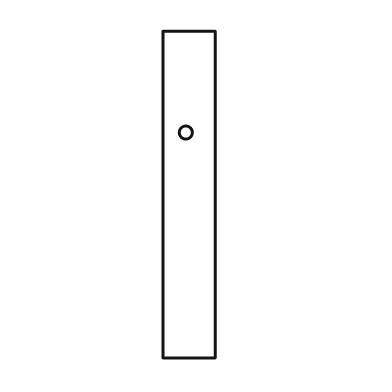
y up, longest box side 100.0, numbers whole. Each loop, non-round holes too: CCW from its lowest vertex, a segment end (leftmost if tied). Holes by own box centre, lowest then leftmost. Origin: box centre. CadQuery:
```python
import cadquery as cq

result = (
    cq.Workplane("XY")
    .moveTo(-8.0, -50.0)
    .lineTo(8.0, -50.0)
    .lineTo(8.0, 50.0)
    .lineTo(-8.0, 50.0)
    .close()
    .moveTo(-1.0, 19.0)
    .circle(2.0)
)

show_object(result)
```